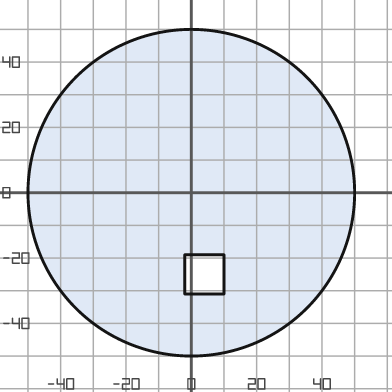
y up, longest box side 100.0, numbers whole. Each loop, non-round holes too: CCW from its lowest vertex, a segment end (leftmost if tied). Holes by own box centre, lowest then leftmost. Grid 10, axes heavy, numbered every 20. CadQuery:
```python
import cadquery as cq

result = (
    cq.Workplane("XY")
    .moveTo(0.0, 0.0)
    .circle(50.0)
    .moveTo(-2.0, -31.0)
    .lineTo(10.0, -31.0)
    .lineTo(10.0, -19.0)
    .lineTo(-2.0, -19.0)
    .close()
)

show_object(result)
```